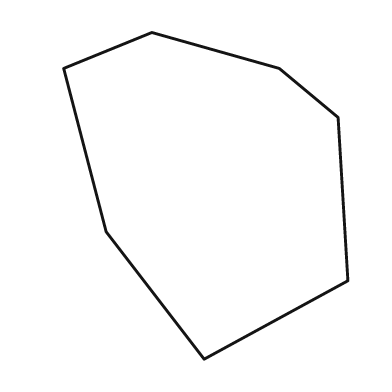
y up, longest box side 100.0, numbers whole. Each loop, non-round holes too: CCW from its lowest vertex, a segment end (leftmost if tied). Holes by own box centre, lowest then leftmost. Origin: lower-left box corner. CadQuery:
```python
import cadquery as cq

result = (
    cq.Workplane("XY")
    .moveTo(43.0, 0.0)
    .lineTo(87.0, 24.0)
    .lineTo(84.0, 74.0)
    .lineTo(66.0, 89.0)
    .lineTo(27.0, 100.0)
    .lineTo(0.0, 89.0)
    .lineTo(13.0, 39.0)
    .close()
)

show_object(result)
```